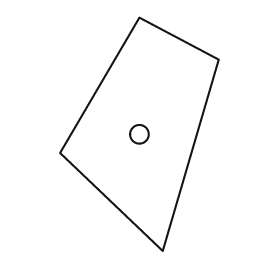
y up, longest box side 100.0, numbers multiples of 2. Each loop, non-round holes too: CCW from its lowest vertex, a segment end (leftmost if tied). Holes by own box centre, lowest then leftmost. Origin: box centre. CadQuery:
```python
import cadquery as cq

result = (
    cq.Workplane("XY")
    .moveTo(10.0, -50.0)
    .lineTo(34.0, 32.0)
    .lineTo(0.0, 50.0)
    .lineTo(-34.0, -8.0)
    .close()
    .moveTo(0.0, 0.0)
    .circle(4.0)
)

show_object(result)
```